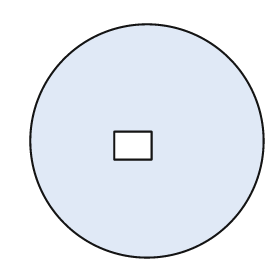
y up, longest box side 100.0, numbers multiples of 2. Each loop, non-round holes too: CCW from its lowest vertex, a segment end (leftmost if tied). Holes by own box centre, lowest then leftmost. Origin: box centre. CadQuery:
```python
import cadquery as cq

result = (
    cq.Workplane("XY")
    .moveTo(0.0, 0.0)
    .circle(50.0)
    .moveTo(-14.0, -8.0)
    .lineTo(2.0, -8.0)
    .lineTo(2.0, 4.0)
    .lineTo(-14.0, 4.0)
    .close()
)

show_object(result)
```